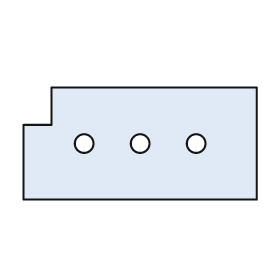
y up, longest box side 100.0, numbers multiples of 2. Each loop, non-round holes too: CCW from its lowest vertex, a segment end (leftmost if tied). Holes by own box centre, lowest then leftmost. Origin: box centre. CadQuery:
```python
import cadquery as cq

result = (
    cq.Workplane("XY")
    .moveTo(-50.0, -24.0)
    .lineTo(50.0, -24.0)
    .lineTo(50.0, 24.0)
    .lineTo(-38.0, 24.0)
    .lineTo(-38.0, 8.0)
    .lineTo(-50.0, 8.0)
    .close()
    .moveTo(-24.0, 0.0)
    .circle(4.0)
    .moveTo(0.0, 0.0)
    .circle(4.0)
    .moveTo(24.0, 0.0)
    .circle(4.0)
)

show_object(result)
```